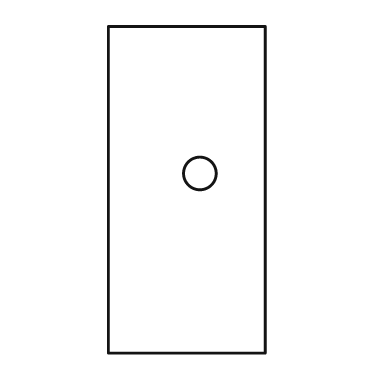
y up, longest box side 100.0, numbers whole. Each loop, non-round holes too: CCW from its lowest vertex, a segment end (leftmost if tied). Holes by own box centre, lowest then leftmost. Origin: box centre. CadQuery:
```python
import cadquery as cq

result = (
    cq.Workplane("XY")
    .moveTo(-24.0, -50.0)
    .lineTo(24.0, -50.0)
    .lineTo(24.0, 50.0)
    .lineTo(-24.0, 50.0)
    .close()
    .moveTo(4.0, 5.0)
    .circle(5.0)
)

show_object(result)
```